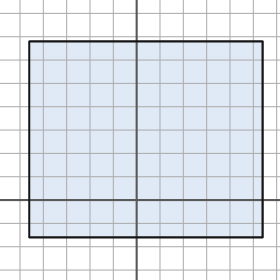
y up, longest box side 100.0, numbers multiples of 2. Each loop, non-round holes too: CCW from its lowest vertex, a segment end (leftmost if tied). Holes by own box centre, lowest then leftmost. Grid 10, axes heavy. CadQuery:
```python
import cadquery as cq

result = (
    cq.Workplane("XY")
    .moveTo(-46.0, -16.0)
    .lineTo(54.0, -16.0)
    .lineTo(54.0, 68.0)
    .lineTo(-46.0, 68.0)
    .close()
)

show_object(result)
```